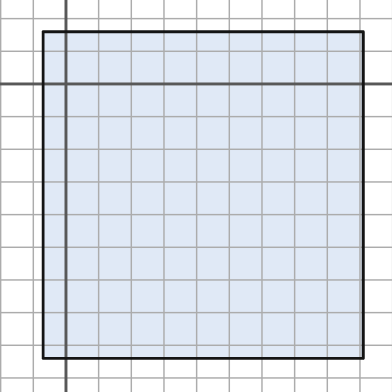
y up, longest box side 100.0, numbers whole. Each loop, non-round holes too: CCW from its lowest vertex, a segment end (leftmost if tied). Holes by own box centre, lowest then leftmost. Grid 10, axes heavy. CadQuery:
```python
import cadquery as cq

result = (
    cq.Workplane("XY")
    .moveTo(-7.0, -84.0)
    .lineTo(91.0, -84.0)
    .lineTo(91.0, 16.0)
    .lineTo(-7.0, 16.0)
    .close()
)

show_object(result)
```